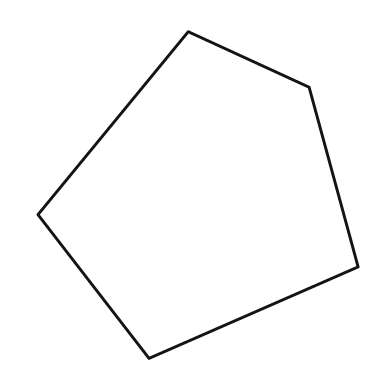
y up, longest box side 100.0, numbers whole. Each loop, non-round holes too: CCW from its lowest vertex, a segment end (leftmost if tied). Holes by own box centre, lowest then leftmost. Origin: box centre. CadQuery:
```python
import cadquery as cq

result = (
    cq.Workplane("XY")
    .moveTo(-15.0, -50.0)
    .lineTo(49.0, -22.0)
    .lineTo(34.0, 33.0)
    .lineTo(-3.0, 50.0)
    .lineTo(-49.0, -6.0)
    .close()
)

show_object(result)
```